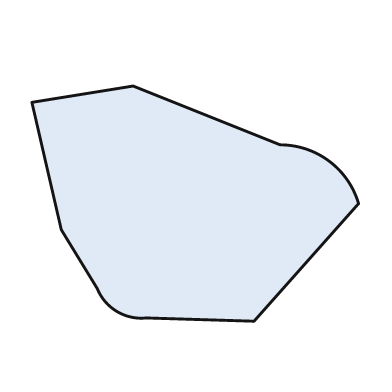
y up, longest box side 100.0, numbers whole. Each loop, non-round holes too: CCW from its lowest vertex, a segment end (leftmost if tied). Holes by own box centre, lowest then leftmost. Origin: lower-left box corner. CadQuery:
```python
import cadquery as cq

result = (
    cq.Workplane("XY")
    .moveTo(68.0, 0.0)
    .lineTo(100.0, 36.0)
    .threePointArc((91.0, 49.0), (76.0, 54.0))
    .lineTo(31.0, 72.0)
    .lineTo(0.0, 67.0)
    .lineTo(9.0, 28.0)
    .lineTo(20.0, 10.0)
    .threePointArc((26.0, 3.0), (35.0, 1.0))
    .close()
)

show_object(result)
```